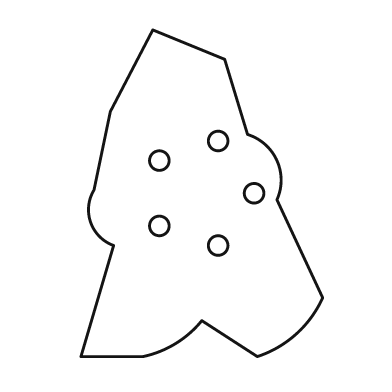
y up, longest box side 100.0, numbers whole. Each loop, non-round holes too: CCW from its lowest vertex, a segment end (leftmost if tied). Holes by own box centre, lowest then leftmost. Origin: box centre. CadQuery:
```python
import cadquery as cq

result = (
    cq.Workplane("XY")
    .moveTo(-37.0, -50.0)
    .lineTo(-18.0, -50.0)
    .threePointArc((-8.0, -46.0), (0.0, -39.0))
    .lineTo(17.0, -50.0)
    .threePointArc((29.0, -43.0), (37.0, -32.0))
    .lineTo(23.0, -2.0)
    .threePointArc((23.0, 10.0), (14.0, 18.0))
    .lineTo(7.0, 41.0)
    .lineTo(-15.0, 50.0)
    .lineTo(-28.0, 25.0)
    .lineTo(-33.0, 1.0)
    .threePointArc((-34.0, -9.0), (-27.0, -16.0))
    .close()
    .moveTo(5.0, -16.0)
    .circle(3.0)
    .moveTo(-13.0, -10.0)
    .circle(3.0)
    .moveTo(16.0, 0.0)
    .circle(3.0)
    .moveTo(-13.0, 10.0)
    .circle(3.0)
    .moveTo(5.0, 16.0)
    .circle(3.0)
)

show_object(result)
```